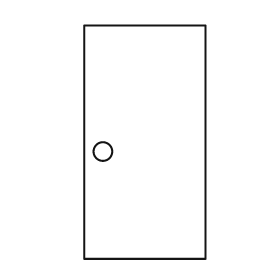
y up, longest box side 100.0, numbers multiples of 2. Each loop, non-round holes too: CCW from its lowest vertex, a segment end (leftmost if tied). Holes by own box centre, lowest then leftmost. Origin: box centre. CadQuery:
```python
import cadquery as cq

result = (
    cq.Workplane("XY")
    .moveTo(-26.0, -50.0)
    .lineTo(26.0, -50.0)
    .lineTo(26.0, 50.0)
    .lineTo(-26.0, 50.0)
    .close()
    .moveTo(-18.0, -4.0)
    .circle(4.0)
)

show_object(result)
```